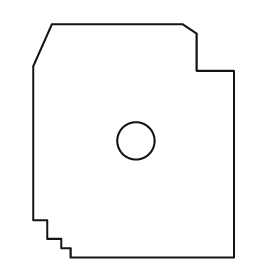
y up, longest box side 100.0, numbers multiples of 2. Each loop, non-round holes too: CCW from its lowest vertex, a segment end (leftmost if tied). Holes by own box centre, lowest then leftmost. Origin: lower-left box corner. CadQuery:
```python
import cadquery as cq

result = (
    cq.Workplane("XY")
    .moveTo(16.0, 0.0)
    .lineTo(86.0, 0.0)
    .lineTo(86.0, 80.0)
    .lineTo(70.0, 80.0)
    .lineTo(70.0, 96.0)
    .lineTo(64.0, 100.0)
    .lineTo(8.0, 100.0)
    .lineTo(0.0, 82.0)
    .lineTo(0.0, 16.0)
    .lineTo(6.0, 16.0)
    .lineTo(6.0, 8.0)
    .lineTo(12.0, 8.0)
    .lineTo(12.0, 4.0)
    .lineTo(16.0, 4.0)
    .close()
    .moveTo(44.0, 50.0)
    .circle(8.0)
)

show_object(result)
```